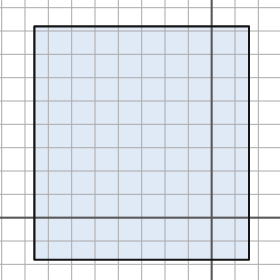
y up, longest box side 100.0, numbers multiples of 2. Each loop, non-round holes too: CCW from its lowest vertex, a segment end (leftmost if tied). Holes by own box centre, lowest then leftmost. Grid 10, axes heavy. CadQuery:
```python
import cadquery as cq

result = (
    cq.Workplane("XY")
    .moveTo(-76.0, -18.0)
    .lineTo(16.0, -18.0)
    .lineTo(16.0, 82.0)
    .lineTo(-76.0, 82.0)
    .close()
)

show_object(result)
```